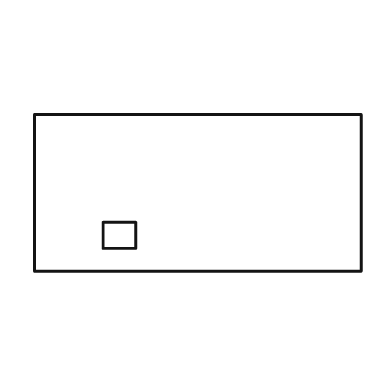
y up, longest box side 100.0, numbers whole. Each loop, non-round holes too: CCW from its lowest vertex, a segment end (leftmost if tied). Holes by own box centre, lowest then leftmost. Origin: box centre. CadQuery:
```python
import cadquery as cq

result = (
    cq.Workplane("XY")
    .moveTo(-50.0, -24.0)
    .lineTo(50.0, -24.0)
    .lineTo(50.0, 24.0)
    .lineTo(-50.0, 24.0)
    .close()
    .moveTo(-29.0, -17.0)
    .lineTo(-19.0, -17.0)
    .lineTo(-19.0, -9.0)
    .lineTo(-29.0, -9.0)
    .close()
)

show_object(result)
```